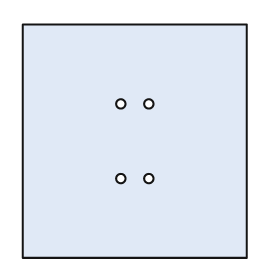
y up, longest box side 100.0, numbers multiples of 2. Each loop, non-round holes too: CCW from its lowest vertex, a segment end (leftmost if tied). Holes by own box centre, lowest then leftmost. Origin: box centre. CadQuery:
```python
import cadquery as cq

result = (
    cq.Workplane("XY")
    .moveTo(-48.0, -50.0)
    .lineTo(48.0, -50.0)
    .lineTo(48.0, 50.0)
    .lineTo(-48.0, 50.0)
    .close()
    .moveTo(-6.0, -16.0)
    .circle(2.0)
    .moveTo(6.0, -16.0)
    .circle(2.0)
    .moveTo(-6.0, 16.0)
    .circle(2.0)
    .moveTo(6.0, 16.0)
    .circle(2.0)
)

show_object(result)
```